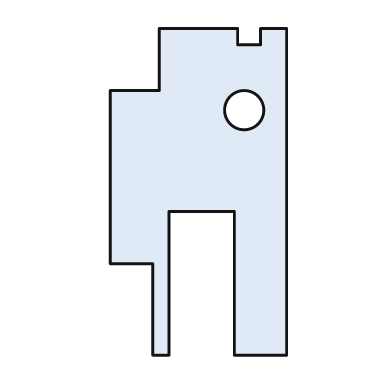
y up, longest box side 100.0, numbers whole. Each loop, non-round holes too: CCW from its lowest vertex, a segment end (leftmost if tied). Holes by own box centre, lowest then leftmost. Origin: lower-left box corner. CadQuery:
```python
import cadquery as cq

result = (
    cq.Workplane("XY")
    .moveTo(13.0, 0.0)
    .lineTo(18.0, 0.0)
    .lineTo(18.0, 44.0)
    .lineTo(38.0, 44.0)
    .lineTo(38.0, 0.0)
    .lineTo(54.0, 0.0)
    .lineTo(54.0, 100.0)
    .lineTo(46.0, 100.0)
    .lineTo(46.0, 95.0)
    .lineTo(39.0, 95.0)
    .lineTo(39.0, 100.0)
    .lineTo(15.0, 100.0)
    .lineTo(15.0, 81.0)
    .lineTo(0.0, 81.0)
    .lineTo(0.0, 28.0)
    .lineTo(13.0, 28.0)
    .close()
    .moveTo(41.0, 75.0)
    .circle(6.0)
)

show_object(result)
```